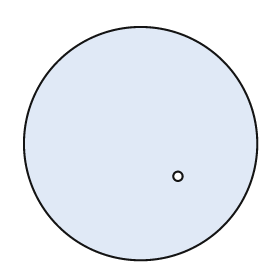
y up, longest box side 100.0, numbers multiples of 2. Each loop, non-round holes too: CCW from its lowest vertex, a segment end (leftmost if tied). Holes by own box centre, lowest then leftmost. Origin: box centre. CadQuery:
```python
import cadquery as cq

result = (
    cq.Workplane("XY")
    .moveTo(0.0, 0.0)
    .circle(50.0)
    .moveTo(16.0, -14.0)
    .circle(2.0)
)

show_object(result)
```